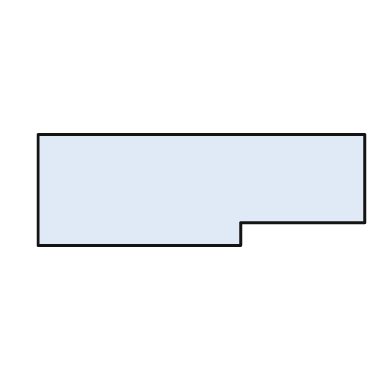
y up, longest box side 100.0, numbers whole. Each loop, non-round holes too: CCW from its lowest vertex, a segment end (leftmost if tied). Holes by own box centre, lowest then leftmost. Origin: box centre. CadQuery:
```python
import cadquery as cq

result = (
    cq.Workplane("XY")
    .moveTo(-50.0, -17.0)
    .lineTo(12.0, -17.0)
    .lineTo(12.0, -10.0)
    .lineTo(50.0, -10.0)
    .lineTo(50.0, 17.0)
    .lineTo(-50.0, 17.0)
    .close()
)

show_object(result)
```